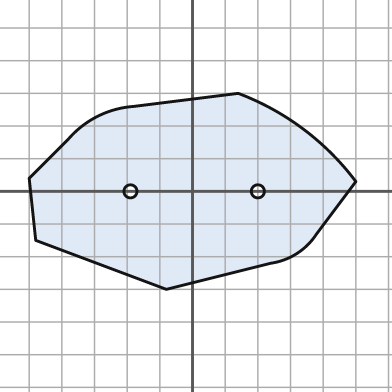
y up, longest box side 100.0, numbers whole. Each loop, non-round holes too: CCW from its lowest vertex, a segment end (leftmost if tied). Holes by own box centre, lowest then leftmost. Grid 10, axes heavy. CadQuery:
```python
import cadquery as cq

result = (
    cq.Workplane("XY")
    .moveTo(-8.0, -30.0)
    .lineTo(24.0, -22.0)
    .threePointArc((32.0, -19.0), (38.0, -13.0))
    .lineTo(50.0, 3.0)
    .threePointArc((34.0, 19.0), (14.0, 30.0))
    .lineTo(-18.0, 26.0)
    .threePointArc((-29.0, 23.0), (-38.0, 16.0))
    .lineTo(-50.0, 4.0)
    .lineTo(-48.0, -15.0)
    .close()
    .moveTo(-19.0, 0.0)
    .circle(2.0)
    .moveTo(20.0, 0.0)
    .circle(2.0)
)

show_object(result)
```